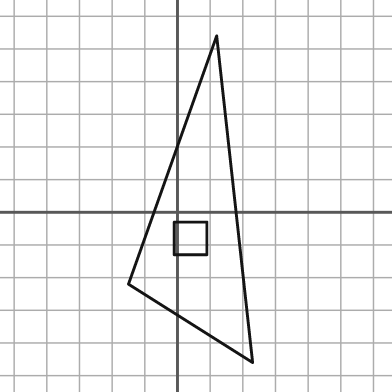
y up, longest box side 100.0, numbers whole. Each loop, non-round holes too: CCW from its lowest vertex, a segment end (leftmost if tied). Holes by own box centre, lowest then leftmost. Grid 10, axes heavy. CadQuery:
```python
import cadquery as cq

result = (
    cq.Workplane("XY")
    .moveTo(23.0, -46.0)
    .lineTo(12.0, 54.0)
    .lineTo(-15.0, -22.0)
    .close()
    .moveTo(-1.0, -13.0)
    .lineTo(9.0, -13.0)
    .lineTo(9.0, -3.0)
    .lineTo(-1.0, -3.0)
    .close()
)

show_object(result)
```